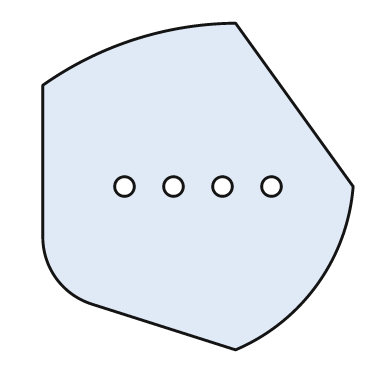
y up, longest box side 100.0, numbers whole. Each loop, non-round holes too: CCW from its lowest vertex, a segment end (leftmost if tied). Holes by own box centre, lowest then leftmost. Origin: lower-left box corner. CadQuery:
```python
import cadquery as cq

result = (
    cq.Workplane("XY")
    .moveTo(59.0, 0.0)
    .threePointArc((84.0, 20.0), (95.0, 50.0))
    .lineTo(59.0, 100.0)
    .threePointArc((28.0, 95.0), (0.0, 81.0))
    .lineTo(0.0, 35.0)
    .threePointArc((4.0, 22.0), (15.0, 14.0))
    .close()
    .moveTo(25.0, 50.0)
    .circle(3.0)
    .moveTo(40.0, 50.0)
    .circle(3.0)
    .moveTo(55.0, 50.0)
    .circle(3.0)
    .moveTo(70.0, 50.0)
    .circle(3.0)
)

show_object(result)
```